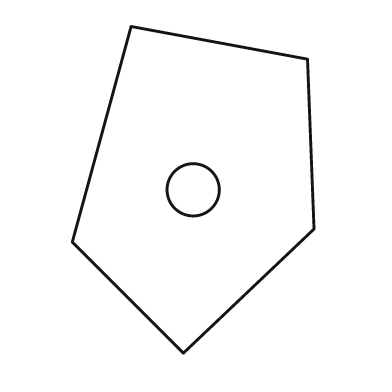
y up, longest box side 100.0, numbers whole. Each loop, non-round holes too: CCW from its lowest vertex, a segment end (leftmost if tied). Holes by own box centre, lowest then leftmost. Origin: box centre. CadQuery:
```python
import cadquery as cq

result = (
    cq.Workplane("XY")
    .moveTo(-3.0, -50.0)
    .lineTo(37.0, -12.0)
    .lineTo(35.0, 40.0)
    .lineTo(-19.0, 50.0)
    .lineTo(-37.0, -16.0)
    .close()
    .moveTo(0.0, 0.0)
    .circle(8.0)
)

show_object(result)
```